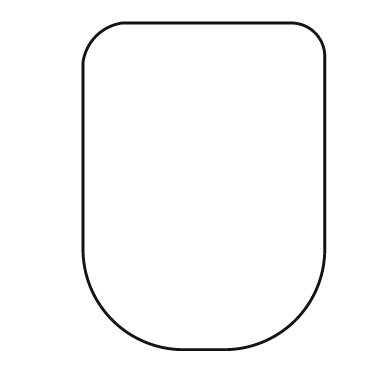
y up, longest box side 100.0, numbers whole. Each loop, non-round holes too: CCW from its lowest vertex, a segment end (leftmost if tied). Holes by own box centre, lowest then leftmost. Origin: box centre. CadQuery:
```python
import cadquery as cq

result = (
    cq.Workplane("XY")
    .moveTo(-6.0, -50.0)
    .lineTo(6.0, -50.0)
    .threePointArc((28.0, -41.0), (37.0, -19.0))
    .lineTo(37.0, 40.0)
    .threePointArc((34.0, 47.0), (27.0, 50.0))
    .lineTo(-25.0, 50.0)
    .threePointArc((-33.0, 46.0), (-37.0, 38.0))
    .lineTo(-37.0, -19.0)
    .threePointArc((-28.0, -41.0), (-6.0, -50.0))
    .close()
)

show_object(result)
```